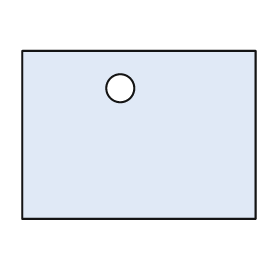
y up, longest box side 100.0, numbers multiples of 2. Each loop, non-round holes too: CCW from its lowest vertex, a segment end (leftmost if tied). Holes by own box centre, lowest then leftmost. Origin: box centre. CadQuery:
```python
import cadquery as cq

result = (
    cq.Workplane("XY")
    .moveTo(-50.0, -36.0)
    .lineTo(50.0, -36.0)
    .lineTo(50.0, 36.0)
    .lineTo(-50.0, 36.0)
    .close()
    .moveTo(-8.0, 20.0)
    .circle(6.0)
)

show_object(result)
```